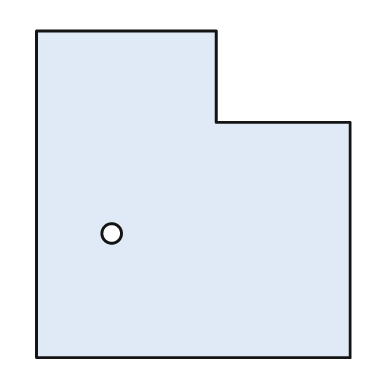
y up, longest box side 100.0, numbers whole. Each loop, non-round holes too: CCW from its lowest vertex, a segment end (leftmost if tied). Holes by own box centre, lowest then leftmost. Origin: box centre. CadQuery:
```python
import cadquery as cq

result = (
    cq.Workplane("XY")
    .moveTo(-48.0, -50.0)
    .lineTo(48.0, -50.0)
    .lineTo(48.0, 22.0)
    .lineTo(7.0, 22.0)
    .lineTo(7.0, 50.0)
    .lineTo(-48.0, 50.0)
    .close()
    .moveTo(-25.0, -12.0)
    .circle(3.0)
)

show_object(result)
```